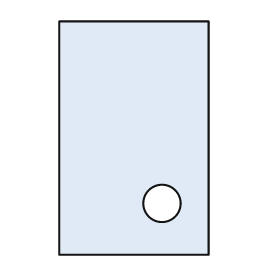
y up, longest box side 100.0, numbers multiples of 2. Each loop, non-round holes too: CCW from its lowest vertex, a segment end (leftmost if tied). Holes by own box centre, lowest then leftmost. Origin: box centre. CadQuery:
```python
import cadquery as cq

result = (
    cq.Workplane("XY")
    .moveTo(-32.0, -50.0)
    .lineTo(32.0, -50.0)
    .lineTo(32.0, 50.0)
    .lineTo(-32.0, 50.0)
    .close()
    .moveTo(12.0, -28.0)
    .circle(8.0)
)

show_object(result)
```